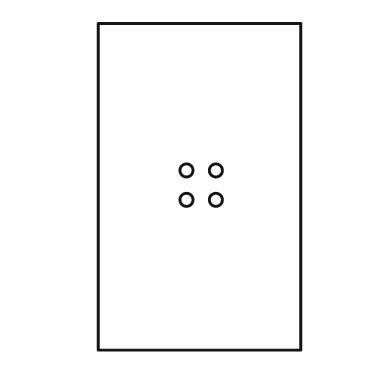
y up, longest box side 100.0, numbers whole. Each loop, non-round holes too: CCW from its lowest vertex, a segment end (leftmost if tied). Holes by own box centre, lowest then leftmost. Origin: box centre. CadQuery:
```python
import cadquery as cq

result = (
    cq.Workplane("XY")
    .moveTo(-31.0, -50.0)
    .lineTo(31.0, -50.0)
    .lineTo(31.0, 50.0)
    .lineTo(-31.0, 50.0)
    .close()
    .moveTo(-4.0, -4.0)
    .circle(2.0)
    .moveTo(5.0, -4.0)
    .circle(2.0)
    .moveTo(-4.0, 5.0)
    .circle(2.0)
    .moveTo(5.0, 5.0)
    .circle(2.0)
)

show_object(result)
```